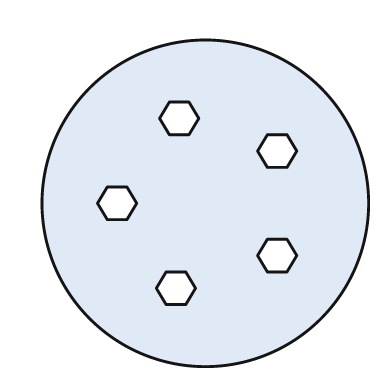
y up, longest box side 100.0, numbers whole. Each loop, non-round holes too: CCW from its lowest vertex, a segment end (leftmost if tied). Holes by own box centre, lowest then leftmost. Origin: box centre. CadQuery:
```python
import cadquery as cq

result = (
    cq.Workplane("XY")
    .moveTo(0.0, 0.0)
    .circle(50.0)
    .moveTo(-12.0, -31.0)
    .lineTo(-6.0, -31.0)
    .lineTo(-3.0, -26.0)
    .lineTo(-6.0, -21.0)
    .lineTo(-12.0, -21.0)
    .lineTo(-15.0, -26.0)
    .close()
    .moveTo(19.0, -21.0)
    .lineTo(25.0, -21.0)
    .lineTo(28.0, -16.0)
    .lineTo(25.0, -11.0)
    .lineTo(19.0, -11.0)
    .lineTo(16.0, -16.0)
    .close()
    .moveTo(-30.0, -5.0)
    .lineTo(-24.0, -5.0)
    .lineTo(-21.0, 0.0)
    .lineTo(-24.0, 5.0)
    .lineTo(-30.0, 5.0)
    .lineTo(-33.0, 0.0)
    .close()
    .moveTo(19.0, 11.0)
    .lineTo(25.0, 11.0)
    .lineTo(28.0, 16.0)
    .lineTo(25.0, 21.0)
    .lineTo(19.0, 21.0)
    .lineTo(16.0, 16.0)
    .close()
    .moveTo(-11.0, 21.0)
    .lineTo(-5.0, 21.0)
    .lineTo(-2.0, 26.0)
    .lineTo(-5.0, 31.0)
    .lineTo(-11.0, 31.0)
    .lineTo(-14.0, 26.0)
    .close()
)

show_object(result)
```